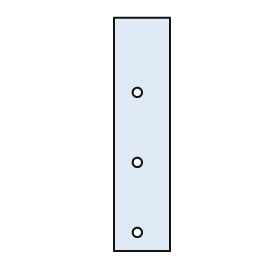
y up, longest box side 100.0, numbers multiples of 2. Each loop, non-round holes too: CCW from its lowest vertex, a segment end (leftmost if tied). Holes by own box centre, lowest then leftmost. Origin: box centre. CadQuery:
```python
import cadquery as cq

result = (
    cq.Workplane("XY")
    .moveTo(-12.0, -50.0)
    .lineTo(12.0, -50.0)
    .lineTo(12.0, 50.0)
    .lineTo(-12.0, 50.0)
    .close()
    .moveTo(-2.0, -42.0)
    .circle(2.0)
    .moveTo(-2.0, -12.0)
    .circle(2.0)
    .moveTo(-2.0, 18.0)
    .circle(2.0)
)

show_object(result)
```